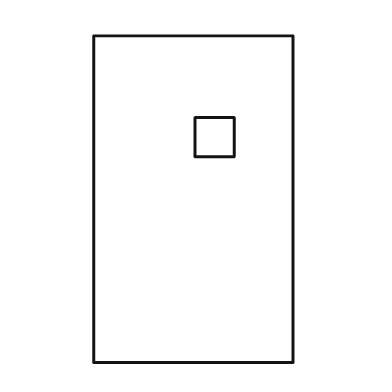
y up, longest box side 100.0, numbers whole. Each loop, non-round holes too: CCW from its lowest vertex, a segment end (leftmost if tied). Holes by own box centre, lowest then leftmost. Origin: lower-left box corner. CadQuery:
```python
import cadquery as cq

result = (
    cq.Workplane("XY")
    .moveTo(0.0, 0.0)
    .lineTo(61.0, 0.0)
    .lineTo(61.0, 100.0)
    .lineTo(0.0, 100.0)
    .close()
    .moveTo(31.0, 63.0)
    .lineTo(43.0, 63.0)
    .lineTo(43.0, 75.0)
    .lineTo(31.0, 75.0)
    .close()
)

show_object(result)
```